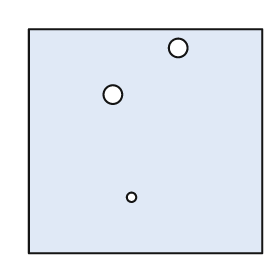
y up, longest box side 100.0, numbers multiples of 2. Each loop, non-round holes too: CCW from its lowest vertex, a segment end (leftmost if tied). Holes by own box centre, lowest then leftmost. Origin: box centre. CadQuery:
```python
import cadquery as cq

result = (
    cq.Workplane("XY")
    .moveTo(-50.0, -48.0)
    .lineTo(50.0, -48.0)
    .lineTo(50.0, 48.0)
    .lineTo(-50.0, 48.0)
    .close()
    .moveTo(-6.0, -24.0)
    .circle(2.0)
    .moveTo(-14.0, 20.0)
    .circle(4.0)
    .moveTo(14.0, 40.0)
    .circle(4.0)
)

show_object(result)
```